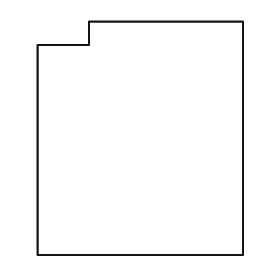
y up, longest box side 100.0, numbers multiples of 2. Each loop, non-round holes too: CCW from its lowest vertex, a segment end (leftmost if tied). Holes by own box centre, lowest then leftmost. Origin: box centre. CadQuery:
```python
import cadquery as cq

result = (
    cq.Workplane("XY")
    .moveTo(-44.0, -50.0)
    .lineTo(44.0, -50.0)
    .lineTo(44.0, 50.0)
    .lineTo(-22.0, 50.0)
    .lineTo(-22.0, 40.0)
    .lineTo(-44.0, 40.0)
    .close()
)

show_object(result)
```